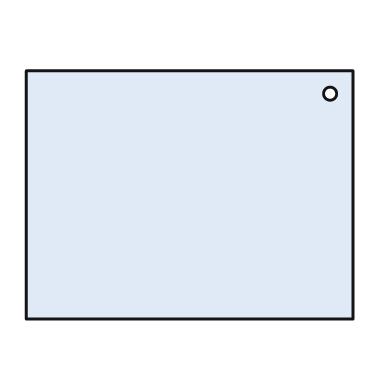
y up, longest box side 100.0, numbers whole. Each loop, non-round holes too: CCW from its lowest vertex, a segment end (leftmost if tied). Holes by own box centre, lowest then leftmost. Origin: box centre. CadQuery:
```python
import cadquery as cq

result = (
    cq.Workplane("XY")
    .moveTo(-50.0, -38.0)
    .lineTo(50.0, -38.0)
    .lineTo(50.0, 38.0)
    .lineTo(-50.0, 38.0)
    .close()
    .moveTo(43.0, 31.0)
    .circle(2.0)
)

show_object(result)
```